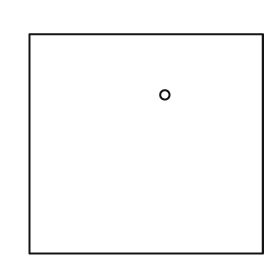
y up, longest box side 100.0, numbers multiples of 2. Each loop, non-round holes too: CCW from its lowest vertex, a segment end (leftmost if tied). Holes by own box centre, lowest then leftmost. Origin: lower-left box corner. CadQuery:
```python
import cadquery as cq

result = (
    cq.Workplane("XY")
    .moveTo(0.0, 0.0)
    .lineTo(100.0, 0.0)
    .lineTo(100.0, 94.0)
    .lineTo(0.0, 94.0)
    .close()
    .moveTo(58.0, 68.0)
    .circle(2.0)
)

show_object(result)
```